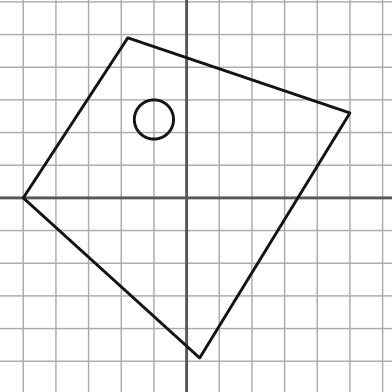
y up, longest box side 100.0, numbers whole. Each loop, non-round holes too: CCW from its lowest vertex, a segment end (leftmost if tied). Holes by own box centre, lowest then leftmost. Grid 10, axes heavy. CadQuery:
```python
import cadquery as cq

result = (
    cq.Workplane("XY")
    .moveTo(4.0, -49.0)
    .lineTo(50.0, 26.0)
    .lineTo(-18.0, 49.0)
    .lineTo(-50.0, 0.0)
    .close()
    .moveTo(-10.0, 24.0)
    .circle(6.0)
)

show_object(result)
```